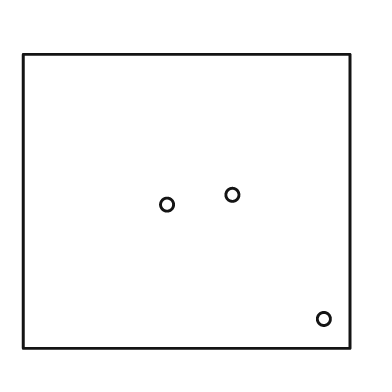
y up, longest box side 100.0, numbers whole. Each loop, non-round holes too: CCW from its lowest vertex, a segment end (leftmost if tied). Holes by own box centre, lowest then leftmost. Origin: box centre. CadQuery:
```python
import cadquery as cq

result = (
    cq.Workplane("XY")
    .moveTo(-50.0, -45.0)
    .lineTo(50.0, -45.0)
    .lineTo(50.0, 45.0)
    .lineTo(-50.0, 45.0)
    .close()
    .moveTo(42.0, -36.0)
    .circle(2.0)
    .moveTo(-6.0, -1.0)
    .circle(2.0)
    .moveTo(14.0, 2.0)
    .circle(2.0)
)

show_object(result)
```